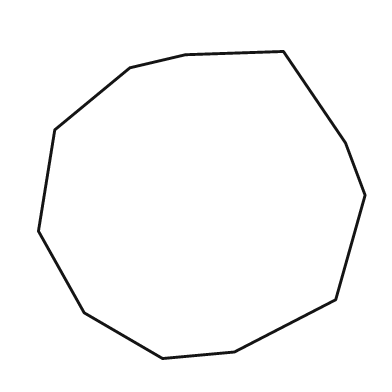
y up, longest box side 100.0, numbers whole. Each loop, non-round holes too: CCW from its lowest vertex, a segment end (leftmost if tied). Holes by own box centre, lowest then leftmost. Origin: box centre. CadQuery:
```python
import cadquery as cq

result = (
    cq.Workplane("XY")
    .moveTo(-12.0, -47.0)
    .lineTo(10.0, -45.0)
    .lineTo(41.0, -29.0)
    .lineTo(50.0, 3.0)
    .lineTo(44.0, 19.0)
    .lineTo(25.0, 47.0)
    .lineTo(-5.0, 46.0)
    .lineTo(-22.0, 42.0)
    .lineTo(-45.0, 23.0)
    .lineTo(-50.0, -8.0)
    .lineTo(-36.0, -33.0)
    .close()
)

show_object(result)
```